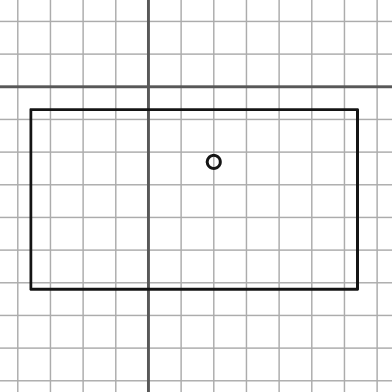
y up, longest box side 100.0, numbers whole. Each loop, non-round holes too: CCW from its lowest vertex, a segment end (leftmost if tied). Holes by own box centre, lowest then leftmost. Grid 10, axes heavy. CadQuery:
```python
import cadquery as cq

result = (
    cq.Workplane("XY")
    .moveTo(-36.0, -62.0)
    .lineTo(64.0, -62.0)
    .lineTo(64.0, -7.0)
    .lineTo(-36.0, -7.0)
    .close()
    .moveTo(20.0, -23.0)
    .circle(2.0)
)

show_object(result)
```